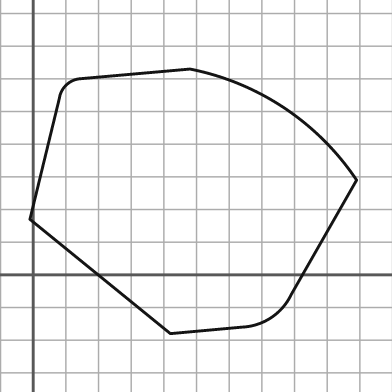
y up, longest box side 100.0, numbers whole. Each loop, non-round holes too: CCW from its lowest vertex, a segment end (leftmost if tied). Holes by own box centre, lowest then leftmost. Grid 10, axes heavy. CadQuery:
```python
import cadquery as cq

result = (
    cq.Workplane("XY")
    .moveTo(42.0, -18.0)
    .lineTo(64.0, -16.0)
    .threePointArc((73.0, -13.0), (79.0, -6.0))
    .lineTo(99.0, 29.0)
    .threePointArc((77.0, 51.0), (48.0, 63.0))
    .lineTo(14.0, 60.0)
    .threePointArc((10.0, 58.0), (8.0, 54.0))
    .lineTo(-1.0, 17.0)
    .close()
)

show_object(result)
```